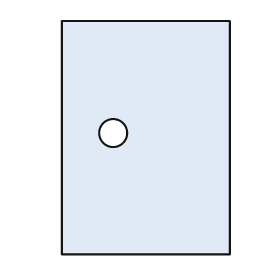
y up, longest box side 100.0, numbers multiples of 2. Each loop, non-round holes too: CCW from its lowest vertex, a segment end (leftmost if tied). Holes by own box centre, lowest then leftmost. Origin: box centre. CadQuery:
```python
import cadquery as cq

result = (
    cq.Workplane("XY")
    .moveTo(-36.0, -50.0)
    .lineTo(36.0, -50.0)
    .lineTo(36.0, 50.0)
    .lineTo(-36.0, 50.0)
    .close()
    .moveTo(-14.0, 2.0)
    .circle(6.0)
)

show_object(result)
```